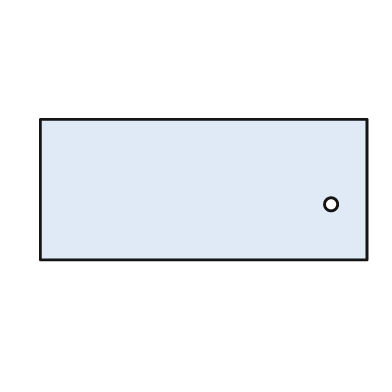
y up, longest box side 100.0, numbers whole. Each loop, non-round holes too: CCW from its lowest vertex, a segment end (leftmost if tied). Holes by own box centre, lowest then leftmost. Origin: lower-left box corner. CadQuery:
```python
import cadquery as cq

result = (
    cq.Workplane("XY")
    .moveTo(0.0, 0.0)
    .lineTo(100.0, 0.0)
    .lineTo(100.0, 43.0)
    .lineTo(0.0, 43.0)
    .close()
    .moveTo(89.0, 17.0)
    .circle(2.0)
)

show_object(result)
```